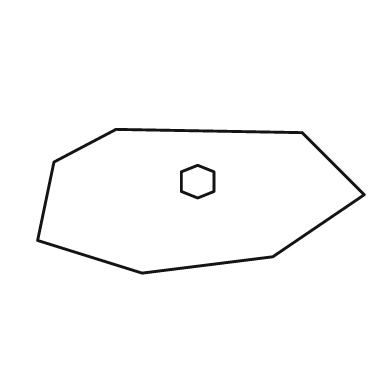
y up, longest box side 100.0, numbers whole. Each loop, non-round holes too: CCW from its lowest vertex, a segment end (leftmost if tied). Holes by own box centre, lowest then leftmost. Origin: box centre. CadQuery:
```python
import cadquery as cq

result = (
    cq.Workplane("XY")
    .moveTo(-18.0, -22.0)
    .lineTo(22.0, -17.0)
    .lineTo(50.0, 2.0)
    .lineTo(31.0, 21.0)
    .lineTo(-26.0, 22.0)
    .lineTo(-45.0, 12.0)
    .lineTo(-50.0, -12.0)
    .close()
    .moveTo(-1.0, 1.0)
    .lineTo(4.0, 3.0)
    .lineTo(4.0, 9.0)
    .lineTo(-1.0, 11.0)
    .lineTo(-6.0, 9.0)
    .lineTo(-6.0, 3.0)
    .close()
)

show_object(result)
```